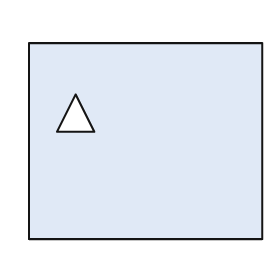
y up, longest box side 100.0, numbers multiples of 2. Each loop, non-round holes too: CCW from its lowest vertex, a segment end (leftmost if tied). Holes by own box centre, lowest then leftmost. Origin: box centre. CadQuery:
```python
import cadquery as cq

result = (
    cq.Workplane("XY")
    .moveTo(-50.0, -42.0)
    .lineTo(50.0, -42.0)
    .lineTo(50.0, 42.0)
    .lineTo(-50.0, 42.0)
    .close()
    .moveTo(-38.0, 4.0)
    .lineTo(-22.0, 4.0)
    .lineTo(-30.0, 20.0)
    .close()
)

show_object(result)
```